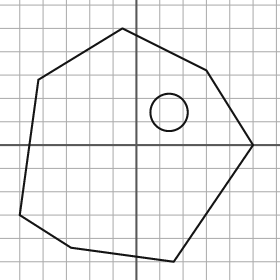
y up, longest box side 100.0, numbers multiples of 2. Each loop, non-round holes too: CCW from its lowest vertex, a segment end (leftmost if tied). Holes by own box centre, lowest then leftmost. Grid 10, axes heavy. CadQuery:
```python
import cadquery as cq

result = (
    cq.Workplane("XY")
    .moveTo(16.0, -50.0)
    .lineTo(50.0, 0.0)
    .lineTo(30.0, 32.0)
    .lineTo(-6.0, 50.0)
    .lineTo(-42.0, 28.0)
    .lineTo(-50.0, -30.0)
    .lineTo(-28.0, -44.0)
    .close()
    .moveTo(14.0, 14.0)
    .circle(8.0)
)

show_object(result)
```